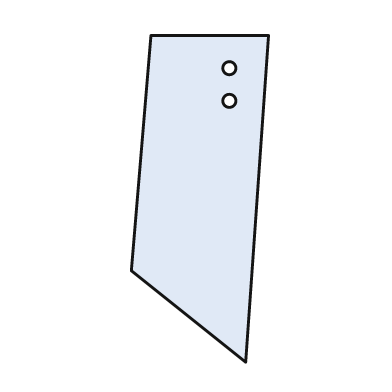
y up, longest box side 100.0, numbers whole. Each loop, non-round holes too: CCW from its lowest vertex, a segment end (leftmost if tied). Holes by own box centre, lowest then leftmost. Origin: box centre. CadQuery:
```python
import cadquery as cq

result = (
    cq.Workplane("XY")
    .moveTo(14.0, -50.0)
    .lineTo(21.0, 50.0)
    .lineTo(-15.0, 50.0)
    .lineTo(-21.0, -22.0)
    .close()
    .moveTo(9.0, 30.0)
    .circle(2.0)
    .moveTo(9.0, 40.0)
    .circle(2.0)
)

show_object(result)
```